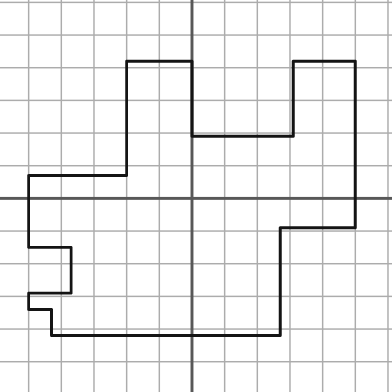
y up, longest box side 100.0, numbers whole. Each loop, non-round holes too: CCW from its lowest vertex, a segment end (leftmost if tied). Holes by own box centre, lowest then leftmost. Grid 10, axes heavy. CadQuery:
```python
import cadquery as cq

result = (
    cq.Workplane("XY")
    .moveTo(-43.0, -42.0)
    .lineTo(27.0, -42.0)
    .lineTo(27.0, -9.0)
    .lineTo(50.0, -9.0)
    .lineTo(50.0, 42.0)
    .lineTo(31.0, 42.0)
    .lineTo(31.0, 19.0)
    .lineTo(0.0, 19.0)
    .lineTo(0.0, 42.0)
    .lineTo(-20.0, 42.0)
    .lineTo(-20.0, 7.0)
    .lineTo(-50.0, 7.0)
    .lineTo(-50.0, -15.0)
    .lineTo(-37.0, -15.0)
    .lineTo(-37.0, -29.0)
    .lineTo(-50.0, -29.0)
    .lineTo(-50.0, -34.0)
    .lineTo(-43.0, -34.0)
    .close()
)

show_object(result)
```